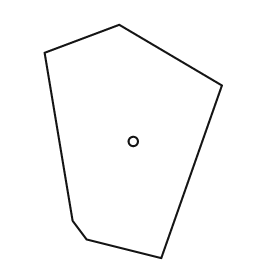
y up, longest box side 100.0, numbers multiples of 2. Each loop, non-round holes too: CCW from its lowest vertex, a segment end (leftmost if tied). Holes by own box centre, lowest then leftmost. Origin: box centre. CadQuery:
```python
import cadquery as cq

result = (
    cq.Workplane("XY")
    .moveTo(12.0, -50.0)
    .lineTo(38.0, 24.0)
    .lineTo(-6.0, 50.0)
    .lineTo(-38.0, 38.0)
    .lineTo(-26.0, -34.0)
    .lineTo(-20.0, -42.0)
    .close()
    .moveTo(0.0, 0.0)
    .circle(2.0)
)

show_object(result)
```